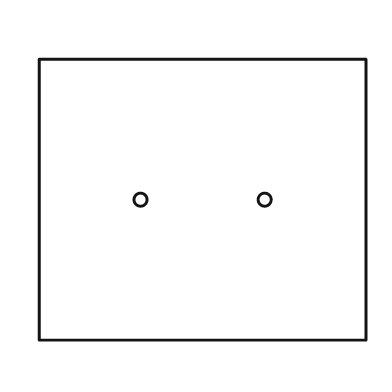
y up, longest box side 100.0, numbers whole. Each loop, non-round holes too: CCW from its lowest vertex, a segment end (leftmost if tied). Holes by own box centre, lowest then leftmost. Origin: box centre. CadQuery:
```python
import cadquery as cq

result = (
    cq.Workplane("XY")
    .moveTo(-50.0, -43.0)
    .lineTo(50.0, -43.0)
    .lineTo(50.0, 43.0)
    .lineTo(-50.0, 43.0)
    .close()
    .moveTo(-19.0, 0.0)
    .circle(2.0)
    .moveTo(19.0, 0.0)
    .circle(2.0)
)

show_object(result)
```